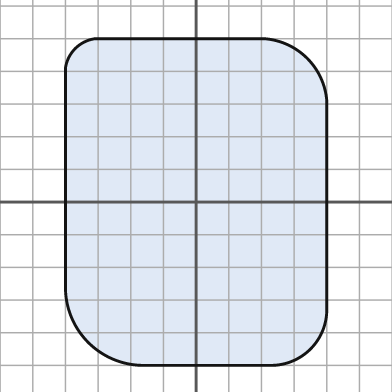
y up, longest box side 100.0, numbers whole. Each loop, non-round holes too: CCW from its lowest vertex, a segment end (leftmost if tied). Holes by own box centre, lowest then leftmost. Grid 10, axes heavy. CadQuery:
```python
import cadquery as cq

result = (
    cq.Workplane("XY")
    .moveTo(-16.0, -50.0)
    .lineTo(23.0, -50.0)
    .threePointArc((35.0, -45.0), (40.0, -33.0))
    .lineTo(40.0, 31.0)
    .threePointArc((34.0, 44.0), (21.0, 50.0))
    .lineTo(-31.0, 50.0)
    .threePointArc((-37.0, 47.0), (-40.0, 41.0))
    .lineTo(-40.0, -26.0)
    .threePointArc((-33.0, -43.0), (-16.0, -50.0))
    .close()
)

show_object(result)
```